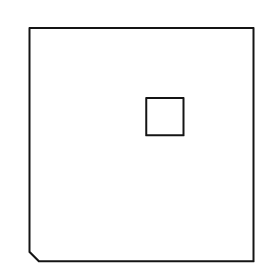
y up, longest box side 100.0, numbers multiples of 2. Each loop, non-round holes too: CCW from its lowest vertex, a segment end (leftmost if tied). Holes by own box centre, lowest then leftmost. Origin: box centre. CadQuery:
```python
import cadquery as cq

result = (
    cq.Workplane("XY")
    .moveTo(-44.0, -50.0)
    .lineTo(48.0, -50.0)
    .lineTo(48.0, 50.0)
    .lineTo(-48.0, 50.0)
    .lineTo(-48.0, -46.0)
    .close()
    .moveTo(2.0, 4.0)
    .lineTo(18.0, 4.0)
    .lineTo(18.0, 20.0)
    .lineTo(2.0, 20.0)
    .close()
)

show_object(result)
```